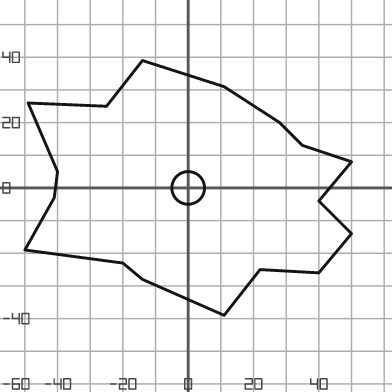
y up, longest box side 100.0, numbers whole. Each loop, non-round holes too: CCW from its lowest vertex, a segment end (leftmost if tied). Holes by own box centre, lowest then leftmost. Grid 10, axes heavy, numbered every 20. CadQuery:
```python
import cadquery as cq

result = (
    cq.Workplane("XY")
    .moveTo(11.0, -39.0)
    .lineTo(22.0, -25.0)
    .lineTo(40.0, -26.0)
    .lineTo(50.0, -14.0)
    .lineTo(40.0, -4.0)
    .lineTo(50.0, 8.0)
    .lineTo(35.0, 13.0)
    .lineTo(28.0, 20.0)
    .lineTo(11.0, 31.0)
    .lineTo(-14.0, 39.0)
    .lineTo(-25.0, 25.0)
    .lineTo(-49.0, 26.0)
    .lineTo(-40.0, 5.0)
    .lineTo(-41.0, -3.0)
    .lineTo(-50.0, -19.0)
    .lineTo(-20.0, -23.0)
    .lineTo(-14.0, -28.0)
    .close()
    .moveTo(0.0, 0.0)
    .circle(5.0)
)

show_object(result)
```